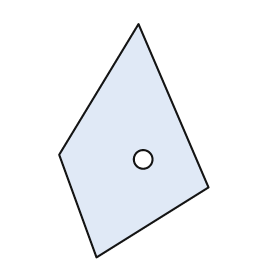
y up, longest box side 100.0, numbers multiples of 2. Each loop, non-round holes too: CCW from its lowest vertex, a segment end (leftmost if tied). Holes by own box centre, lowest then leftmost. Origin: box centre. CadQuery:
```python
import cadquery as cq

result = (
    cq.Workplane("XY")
    .moveTo(-16.0, -50.0)
    .lineTo(32.0, -20.0)
    .lineTo(2.0, 50.0)
    .lineTo(-32.0, -6.0)
    .close()
    .moveTo(4.0, -8.0)
    .circle(4.0)
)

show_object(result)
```